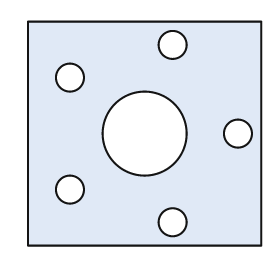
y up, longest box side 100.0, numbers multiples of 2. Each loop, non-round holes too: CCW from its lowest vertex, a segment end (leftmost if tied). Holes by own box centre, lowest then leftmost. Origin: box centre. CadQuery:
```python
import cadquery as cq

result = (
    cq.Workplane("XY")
    .moveTo(-50.0, -48.0)
    .lineTo(50.0, -48.0)
    .lineTo(50.0, 48.0)
    .lineTo(-50.0, 48.0)
    .close()
    .moveTo(12.0, -38.0)
    .circle(6.0)
    .moveTo(-32.0, -24.0)
    .circle(6.0)
    .moveTo(0.0, 0.0)
    .circle(18.0)
    .moveTo(40.0, 0.0)
    .circle(6.0)
    .moveTo(-32.0, 24.0)
    .circle(6.0)
    .moveTo(12.0, 38.0)
    .circle(6.0)
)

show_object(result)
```